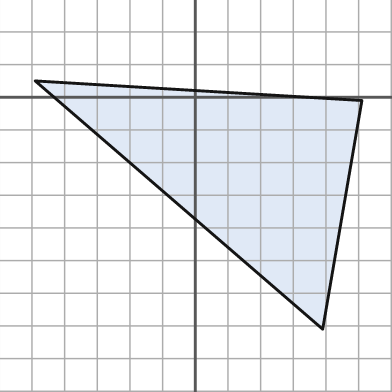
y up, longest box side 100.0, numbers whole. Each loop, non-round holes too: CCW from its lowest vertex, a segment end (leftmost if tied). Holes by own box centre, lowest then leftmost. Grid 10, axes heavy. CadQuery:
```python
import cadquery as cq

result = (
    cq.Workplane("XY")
    .moveTo(39.0, -71.0)
    .lineTo(51.0, -1.0)
    .lineTo(-49.0, 5.0)
    .close()
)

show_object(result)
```